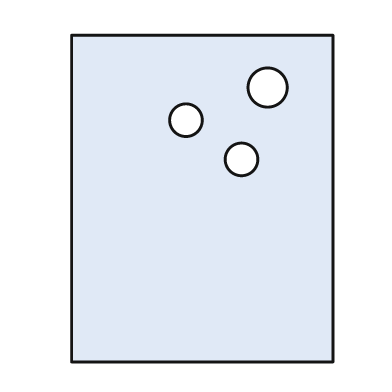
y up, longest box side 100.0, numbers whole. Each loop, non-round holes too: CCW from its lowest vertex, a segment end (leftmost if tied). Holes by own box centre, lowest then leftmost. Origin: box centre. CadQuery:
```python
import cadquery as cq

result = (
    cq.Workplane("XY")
    .moveTo(-40.0, -50.0)
    .lineTo(40.0, -50.0)
    .lineTo(40.0, 50.0)
    .lineTo(-40.0, 50.0)
    .close()
    .moveTo(12.0, 12.0)
    .circle(5.0)
    .moveTo(-5.0, 24.0)
    .circle(5.0)
    .moveTo(20.0, 34.0)
    .circle(6.0)
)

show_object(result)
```